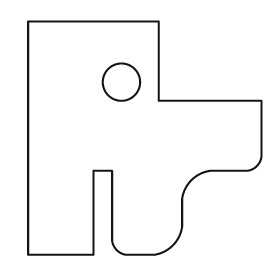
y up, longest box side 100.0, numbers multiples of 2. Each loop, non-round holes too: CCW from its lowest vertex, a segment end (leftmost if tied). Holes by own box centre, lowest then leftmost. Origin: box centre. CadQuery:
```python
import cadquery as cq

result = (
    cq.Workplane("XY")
    .moveTo(-50.0, -50.0)
    .lineTo(-22.0, -50.0)
    .lineTo(-22.0, -14.0)
    .lineTo(-14.0, -14.0)
    .lineTo(-14.0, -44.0)
    .threePointArc((-12.0, -48.0), (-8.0, -50.0))
    .lineTo(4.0, -50.0)
    .threePointArc((12.0, -46.0), (16.0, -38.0))
    .lineTo(16.0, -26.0)
    .threePointArc((20.0, -18.0), (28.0, -14.0))
    .lineTo(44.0, -14.0)
    .threePointArc((48.0, -12.0), (50.0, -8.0))
    .lineTo(50.0, 16.0)
    .lineTo(6.0, 16.0)
    .lineTo(6.0, 50.0)
    .lineTo(-50.0, 50.0)
    .close()
    .moveTo(-10.0, 24.0)
    .circle(8.0)
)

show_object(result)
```